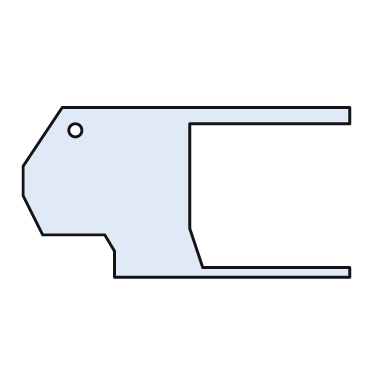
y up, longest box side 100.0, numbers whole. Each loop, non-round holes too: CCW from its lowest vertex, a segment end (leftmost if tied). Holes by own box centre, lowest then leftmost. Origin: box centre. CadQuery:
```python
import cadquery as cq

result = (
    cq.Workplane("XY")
    .moveTo(-22.0, -26.0)
    .lineTo(50.0, -26.0)
    .lineTo(50.0, -23.0)
    .lineTo(5.0, -23.0)
    .lineTo(1.0, -11.0)
    .lineTo(1.0, 21.0)
    .lineTo(50.0, 21.0)
    .lineTo(50.0, 26.0)
    .lineTo(-38.0, 26.0)
    .lineTo(-50.0, 8.0)
    .lineTo(-50.0, -1.0)
    .lineTo(-44.0, -13.0)
    .lineTo(-25.0, -13.0)
    .lineTo(-22.0, -18.0)
    .close()
    .moveTo(-34.0, 19.0)
    .circle(2.0)
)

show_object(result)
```